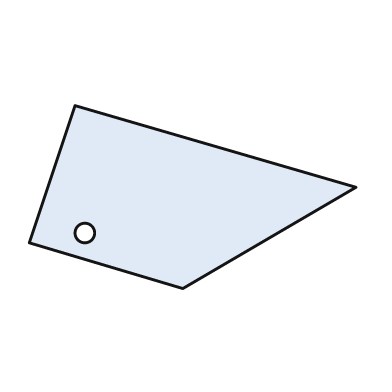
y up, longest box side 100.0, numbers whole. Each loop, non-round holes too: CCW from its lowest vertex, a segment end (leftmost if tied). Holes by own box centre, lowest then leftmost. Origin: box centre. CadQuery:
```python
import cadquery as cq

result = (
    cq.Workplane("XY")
    .moveTo(-3.0, -28.0)
    .lineTo(50.0, 3.0)
    .lineTo(-36.0, 28.0)
    .lineTo(-50.0, -14.0)
    .close()
    .moveTo(-33.0, -11.0)
    .circle(3.0)
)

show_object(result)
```